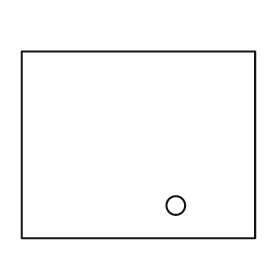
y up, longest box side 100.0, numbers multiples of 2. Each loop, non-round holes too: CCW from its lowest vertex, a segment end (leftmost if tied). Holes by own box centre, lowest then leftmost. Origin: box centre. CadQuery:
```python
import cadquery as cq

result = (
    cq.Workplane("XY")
    .moveTo(-50.0, -40.0)
    .lineTo(50.0, -40.0)
    .lineTo(50.0, 40.0)
    .lineTo(-50.0, 40.0)
    .close()
    .moveTo(16.0, -26.0)
    .circle(4.0)
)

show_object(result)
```